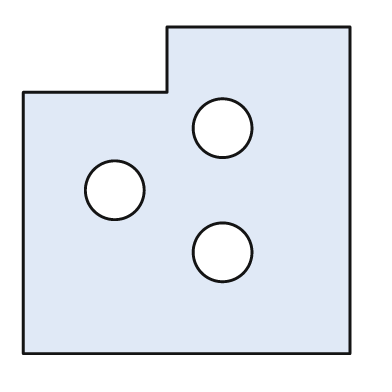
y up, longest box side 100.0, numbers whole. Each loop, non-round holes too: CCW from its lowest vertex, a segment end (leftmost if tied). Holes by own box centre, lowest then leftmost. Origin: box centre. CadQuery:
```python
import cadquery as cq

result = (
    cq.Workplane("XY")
    .moveTo(-50.0, -50.0)
    .lineTo(50.0, -50.0)
    .lineTo(50.0, 50.0)
    .lineTo(-6.0, 50.0)
    .lineTo(-6.0, 30.0)
    .lineTo(-50.0, 30.0)
    .close()
    .moveTo(11.0, -19.0)
    .circle(9.0)
    .moveTo(-22.0, 0.0)
    .circle(9.0)
    .moveTo(11.0, 19.0)
    .circle(9.0)
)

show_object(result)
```